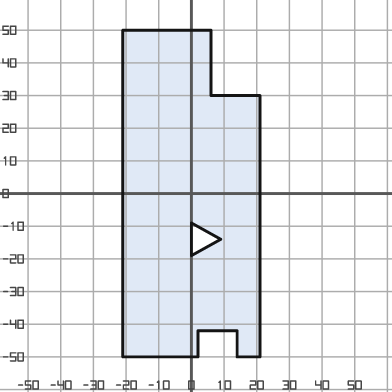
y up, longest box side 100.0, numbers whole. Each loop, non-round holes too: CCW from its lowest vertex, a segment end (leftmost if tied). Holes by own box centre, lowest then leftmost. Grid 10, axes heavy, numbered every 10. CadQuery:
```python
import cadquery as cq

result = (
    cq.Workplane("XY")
    .moveTo(-21.0, -50.0)
    .lineTo(2.0, -50.0)
    .lineTo(2.0, -42.0)
    .lineTo(14.0, -42.0)
    .lineTo(14.0, -50.0)
    .lineTo(21.0, -50.0)
    .lineTo(21.0, 30.0)
    .lineTo(6.0, 30.0)
    .lineTo(6.0, 50.0)
    .lineTo(-21.0, 50.0)
    .close()
    .moveTo(0.0, -19.0)
    .lineTo(9.0, -14.0)
    .lineTo(0.0, -9.0)
    .close()
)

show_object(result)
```